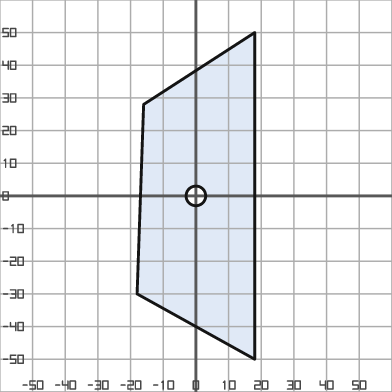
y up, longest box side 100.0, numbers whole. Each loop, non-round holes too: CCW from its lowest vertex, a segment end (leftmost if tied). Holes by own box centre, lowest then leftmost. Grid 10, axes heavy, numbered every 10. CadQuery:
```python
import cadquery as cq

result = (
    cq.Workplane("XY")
    .moveTo(18.0, -50.0)
    .lineTo(18.0, 50.0)
    .lineTo(-16.0, 28.0)
    .lineTo(-18.0, -30.0)
    .close()
    .moveTo(0.0, 0.0)
    .circle(3.0)
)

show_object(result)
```